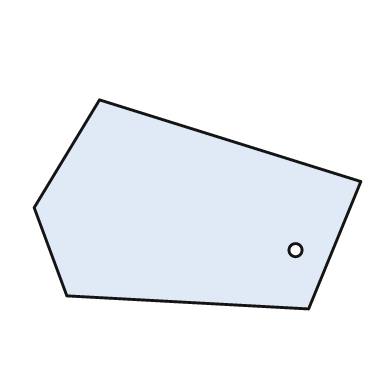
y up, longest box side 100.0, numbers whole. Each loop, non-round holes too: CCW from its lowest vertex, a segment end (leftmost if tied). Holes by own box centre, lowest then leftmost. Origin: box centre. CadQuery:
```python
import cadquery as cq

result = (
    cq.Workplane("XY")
    .moveTo(34.0, -32.0)
    .lineTo(50.0, 7.0)
    .lineTo(-30.0, 32.0)
    .lineTo(-50.0, -1.0)
    .lineTo(-40.0, -28.0)
    .close()
    .moveTo(30.0, -14.0)
    .circle(2.0)
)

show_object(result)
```